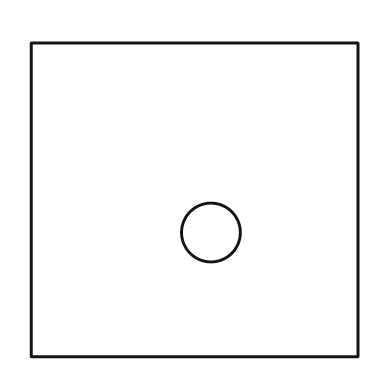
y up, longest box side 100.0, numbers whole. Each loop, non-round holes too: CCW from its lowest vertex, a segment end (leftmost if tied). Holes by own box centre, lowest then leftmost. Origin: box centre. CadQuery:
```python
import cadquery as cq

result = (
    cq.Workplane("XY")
    .moveTo(-50.0, -48.0)
    .lineTo(50.0, -48.0)
    .lineTo(50.0, 48.0)
    .lineTo(-50.0, 48.0)
    .close()
    .moveTo(5.0, -10.0)
    .circle(9.0)
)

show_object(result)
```